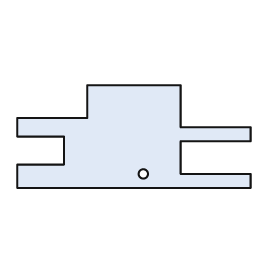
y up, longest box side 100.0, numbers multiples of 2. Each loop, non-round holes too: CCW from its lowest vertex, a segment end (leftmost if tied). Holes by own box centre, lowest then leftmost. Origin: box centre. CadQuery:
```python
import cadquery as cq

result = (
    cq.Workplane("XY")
    .moveTo(-50.0, -22.0)
    .lineTo(50.0, -22.0)
    .lineTo(50.0, -16.0)
    .lineTo(20.0, -16.0)
    .lineTo(20.0, -2.0)
    .lineTo(50.0, -2.0)
    .lineTo(50.0, 4.0)
    .lineTo(20.0, 4.0)
    .lineTo(20.0, 22.0)
    .lineTo(-20.0, 22.0)
    .lineTo(-20.0, 8.0)
    .lineTo(-50.0, 8.0)
    .lineTo(-50.0, 0.0)
    .lineTo(-30.0, 0.0)
    .lineTo(-30.0, -12.0)
    .lineTo(-50.0, -12.0)
    .close()
    .moveTo(4.0, -16.0)
    .circle(2.0)
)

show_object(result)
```